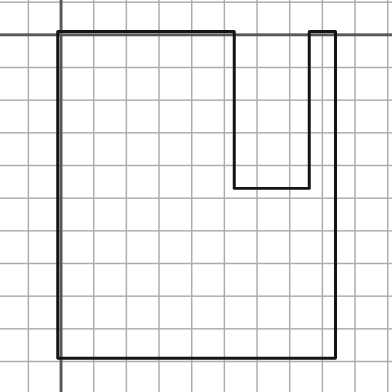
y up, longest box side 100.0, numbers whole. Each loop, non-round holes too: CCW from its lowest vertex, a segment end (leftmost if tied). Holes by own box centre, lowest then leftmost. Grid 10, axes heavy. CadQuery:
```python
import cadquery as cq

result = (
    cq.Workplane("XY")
    .moveTo(-1.0, -99.0)
    .lineTo(84.0, -99.0)
    .lineTo(84.0, 1.0)
    .lineTo(76.0, 1.0)
    .lineTo(76.0, -47.0)
    .lineTo(53.0, -47.0)
    .lineTo(53.0, 1.0)
    .lineTo(-1.0, 1.0)
    .close()
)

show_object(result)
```